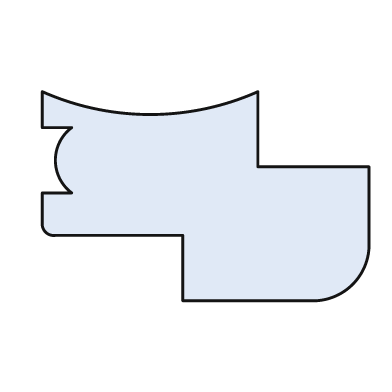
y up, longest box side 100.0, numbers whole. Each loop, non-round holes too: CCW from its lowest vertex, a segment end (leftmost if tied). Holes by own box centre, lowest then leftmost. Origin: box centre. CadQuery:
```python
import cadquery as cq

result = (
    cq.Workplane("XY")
    .moveTo(-7.0, -32.0)
    .lineTo(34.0, -32.0)
    .threePointArc((45.0, -27.0), (50.0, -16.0))
    .lineTo(50.0, 9.0)
    .lineTo(16.0, 9.0)
    .lineTo(16.0, 32.0)
    .threePointArc((-17.0, 25.0), (-50.0, 32.0))
    .lineTo(-50.0, 21.0)
    .lineTo(-41.0, 21.0)
    .threePointArc((-46.0, 11.0), (-41.0, 1.0))
    .lineTo(-50.0, 1.0)
    .lineTo(-50.0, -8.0)
    .threePointArc((-49.0, -11.0), (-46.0, -12.0))
    .lineTo(-7.0, -12.0)
    .close()
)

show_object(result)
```